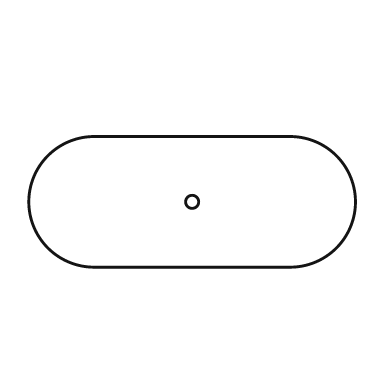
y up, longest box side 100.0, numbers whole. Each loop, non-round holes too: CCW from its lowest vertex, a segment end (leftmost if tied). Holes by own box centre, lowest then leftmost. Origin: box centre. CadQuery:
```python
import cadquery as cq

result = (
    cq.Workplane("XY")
    .moveTo(-30.0, -20.0)
    .lineTo(30.0, -20.0)
    .threePointArc((50.0, 0.0), (30.0, 20.0))
    .lineTo(-30.0, 20.0)
    .threePointArc((-50.0, 0.0), (-30.0, -20.0))
    .close()
    .moveTo(0.0, 0.0)
    .circle(2.0)
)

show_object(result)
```